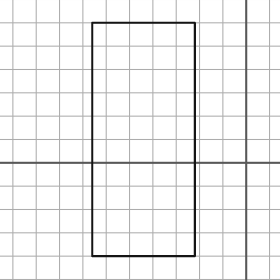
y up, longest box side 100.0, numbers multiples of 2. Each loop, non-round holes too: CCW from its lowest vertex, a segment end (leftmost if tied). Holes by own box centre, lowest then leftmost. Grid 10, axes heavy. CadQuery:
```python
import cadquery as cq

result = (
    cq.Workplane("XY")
    .moveTo(-66.0, -40.0)
    .lineTo(-22.0, -40.0)
    .lineTo(-22.0, 60.0)
    .lineTo(-66.0, 60.0)
    .close()
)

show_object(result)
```